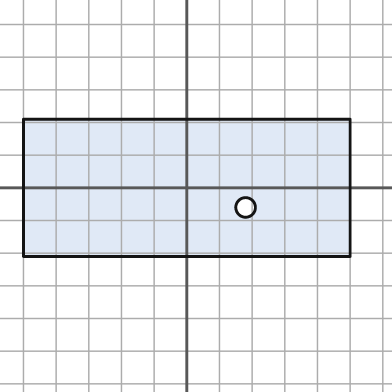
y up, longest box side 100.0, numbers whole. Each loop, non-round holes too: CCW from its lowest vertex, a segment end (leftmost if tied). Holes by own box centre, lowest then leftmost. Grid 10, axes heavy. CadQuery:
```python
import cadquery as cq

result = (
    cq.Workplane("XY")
    .moveTo(-50.0, -21.0)
    .lineTo(50.0, -21.0)
    .lineTo(50.0, 21.0)
    .lineTo(-50.0, 21.0)
    .close()
    .moveTo(18.0, -6.0)
    .circle(3.0)
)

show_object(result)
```